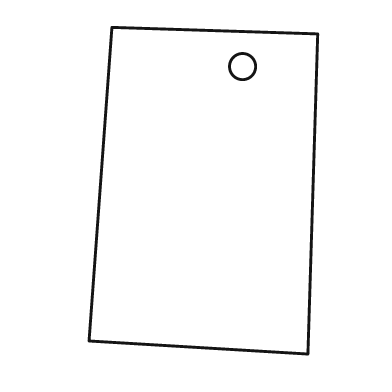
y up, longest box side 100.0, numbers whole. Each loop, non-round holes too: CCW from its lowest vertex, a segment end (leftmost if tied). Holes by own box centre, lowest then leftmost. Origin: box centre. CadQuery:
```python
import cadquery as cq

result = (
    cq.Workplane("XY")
    .moveTo(32.0, -50.0)
    .lineTo(35.0, 48.0)
    .lineTo(-28.0, 50.0)
    .lineTo(-35.0, -46.0)
    .close()
    .moveTo(12.0, 38.0)
    .circle(4.0)
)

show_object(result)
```